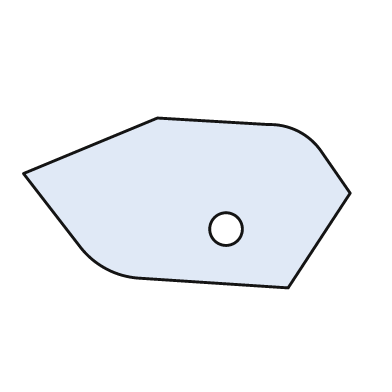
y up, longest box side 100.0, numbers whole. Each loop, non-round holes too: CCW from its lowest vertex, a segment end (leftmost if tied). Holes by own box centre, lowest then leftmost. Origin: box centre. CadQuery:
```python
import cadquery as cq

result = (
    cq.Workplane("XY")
    .moveTo(31.0, -26.0)
    .lineTo(50.0, 3.0)
    .lineTo(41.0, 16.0)
    .threePointArc((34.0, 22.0), (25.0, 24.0))
    .lineTo(-9.0, 26.0)
    .lineTo(-50.0, 9.0)
    .lineTo(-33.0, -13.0)
    .threePointArc((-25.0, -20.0), (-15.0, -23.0))
    .close()
    .moveTo(12.0, -8.0)
    .circle(5.0)
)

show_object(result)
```